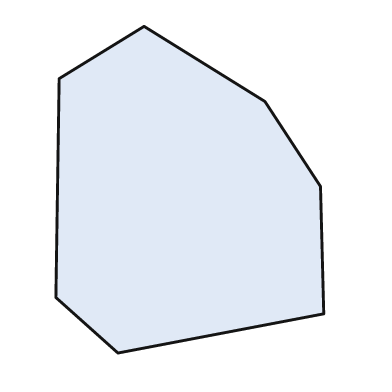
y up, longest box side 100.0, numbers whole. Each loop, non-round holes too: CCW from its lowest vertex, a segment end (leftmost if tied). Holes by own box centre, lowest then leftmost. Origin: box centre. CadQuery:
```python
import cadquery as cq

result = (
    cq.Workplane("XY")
    .moveTo(-22.0, -50.0)
    .lineTo(41.0, -38.0)
    .lineTo(40.0, 1.0)
    .lineTo(23.0, 27.0)
    .lineTo(-14.0, 50.0)
    .lineTo(-40.0, 34.0)
    .lineTo(-41.0, -33.0)
    .close()
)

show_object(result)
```